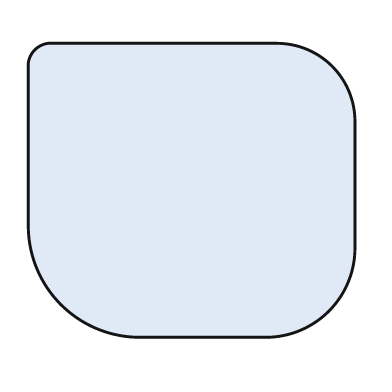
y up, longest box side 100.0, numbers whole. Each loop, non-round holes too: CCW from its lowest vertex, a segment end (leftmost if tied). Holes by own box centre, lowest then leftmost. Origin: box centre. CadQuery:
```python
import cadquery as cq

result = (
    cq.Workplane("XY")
    .moveTo(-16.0, -45.0)
    .lineTo(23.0, -45.0)
    .threePointArc((42.0, -37.0), (50.0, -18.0))
    .lineTo(50.0, 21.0)
    .threePointArc((43.0, 38.0), (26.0, 45.0))
    .lineTo(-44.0, 45.0)
    .threePointArc((-48.0, 43.0), (-50.0, 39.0))
    .lineTo(-50.0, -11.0)
    .threePointArc((-40.0, -35.0), (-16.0, -45.0))
    .close()
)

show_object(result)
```